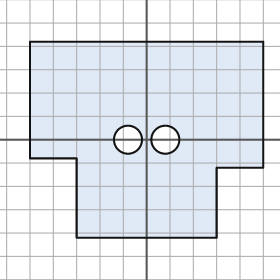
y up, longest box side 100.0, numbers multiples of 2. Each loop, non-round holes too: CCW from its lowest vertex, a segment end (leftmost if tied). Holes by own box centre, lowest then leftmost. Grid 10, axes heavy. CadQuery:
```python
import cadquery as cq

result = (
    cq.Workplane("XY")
    .moveTo(-30.0, -42.0)
    .lineTo(30.0, -42.0)
    .lineTo(30.0, -12.0)
    .lineTo(50.0, -12.0)
    .lineTo(50.0, 42.0)
    .lineTo(-50.0, 42.0)
    .lineTo(-50.0, -8.0)
    .lineTo(-30.0, -8.0)
    .close()
    .moveTo(-8.0, 0.0)
    .circle(6.0)
    .moveTo(8.0, 0.0)
    .circle(6.0)
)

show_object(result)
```